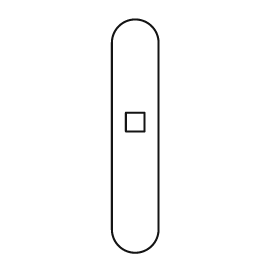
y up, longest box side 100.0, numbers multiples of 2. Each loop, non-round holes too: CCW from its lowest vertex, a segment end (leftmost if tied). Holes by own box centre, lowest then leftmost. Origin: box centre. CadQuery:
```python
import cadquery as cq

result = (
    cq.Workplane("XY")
    .moveTo(-10.0, -40.0)
    .threePointArc((0.0, -50.0), (10.0, -40.0))
    .lineTo(10.0, 40.0)
    .threePointArc((0.0, 50.0), (-10.0, 40.0))
    .close()
    .moveTo(-4.0, 2.0)
    .lineTo(4.0, 2.0)
    .lineTo(4.0, 10.0)
    .lineTo(-4.0, 10.0)
    .close()
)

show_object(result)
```